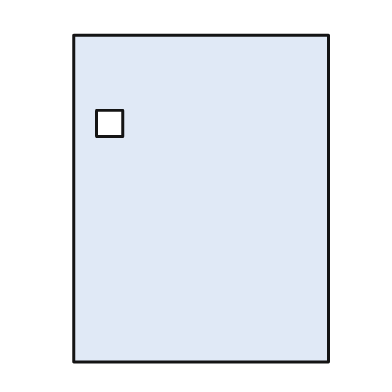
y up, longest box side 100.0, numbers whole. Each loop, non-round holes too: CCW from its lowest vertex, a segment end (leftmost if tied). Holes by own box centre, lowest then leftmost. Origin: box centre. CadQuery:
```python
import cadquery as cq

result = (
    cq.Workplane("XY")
    .moveTo(-39.0, -50.0)
    .lineTo(39.0, -50.0)
    .lineTo(39.0, 50.0)
    .lineTo(-39.0, 50.0)
    .close()
    .moveTo(-32.0, 19.0)
    .lineTo(-24.0, 19.0)
    .lineTo(-24.0, 27.0)
    .lineTo(-32.0, 27.0)
    .close()
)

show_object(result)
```